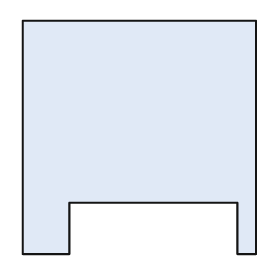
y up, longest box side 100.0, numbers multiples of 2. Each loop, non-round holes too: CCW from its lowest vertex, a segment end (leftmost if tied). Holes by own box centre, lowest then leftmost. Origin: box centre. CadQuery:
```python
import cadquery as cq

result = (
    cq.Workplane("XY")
    .moveTo(-50.0, -50.0)
    .lineTo(-30.0, -50.0)
    .lineTo(-30.0, -28.0)
    .lineTo(42.0, -28.0)
    .lineTo(42.0, -50.0)
    .lineTo(50.0, -50.0)
    .lineTo(50.0, 50.0)
    .lineTo(-50.0, 50.0)
    .close()
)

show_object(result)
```